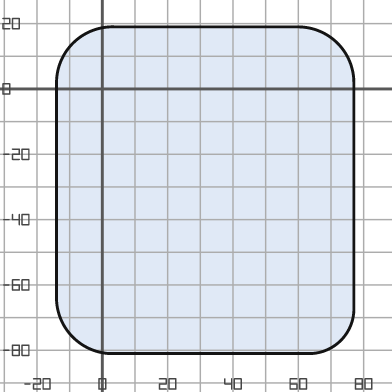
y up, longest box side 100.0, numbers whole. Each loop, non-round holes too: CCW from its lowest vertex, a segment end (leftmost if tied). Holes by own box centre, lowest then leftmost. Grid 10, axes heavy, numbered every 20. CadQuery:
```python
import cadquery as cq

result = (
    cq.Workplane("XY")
    .moveTo(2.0, -81.0)
    .lineTo(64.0, -81.0)
    .threePointArc((73.0, -77.0), (77.0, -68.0))
    .lineTo(77.0, 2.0)
    .threePointArc((72.0, 14.0), (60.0, 19.0))
    .lineTo(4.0, 19.0)
    .threePointArc((-9.0, 14.0), (-14.0, 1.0))
    .lineTo(-14.0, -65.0)
    .threePointArc((-9.0, -76.0), (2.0, -81.0))
    .close()
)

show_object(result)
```